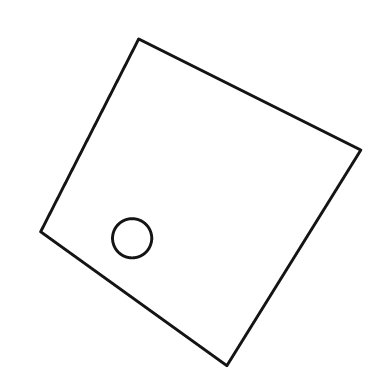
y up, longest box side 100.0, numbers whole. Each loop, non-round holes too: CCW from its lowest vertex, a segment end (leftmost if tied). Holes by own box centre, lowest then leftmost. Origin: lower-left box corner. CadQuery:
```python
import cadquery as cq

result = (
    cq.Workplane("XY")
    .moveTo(57.0, 0.0)
    .lineTo(98.0, 66.0)
    .lineTo(30.0, 100.0)
    .lineTo(0.0, 41.0)
    .close()
    .moveTo(28.0, 39.0)
    .circle(6.0)
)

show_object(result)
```